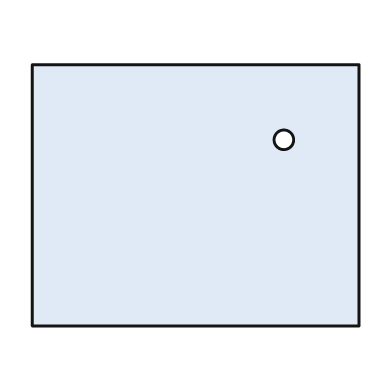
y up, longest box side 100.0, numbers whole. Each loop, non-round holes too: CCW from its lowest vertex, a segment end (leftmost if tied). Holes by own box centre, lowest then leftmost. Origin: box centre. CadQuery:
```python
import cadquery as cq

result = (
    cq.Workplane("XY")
    .moveTo(-50.0, -40.0)
    .lineTo(50.0, -40.0)
    .lineTo(50.0, 40.0)
    .lineTo(-50.0, 40.0)
    .close()
    .moveTo(27.0, 17.0)
    .circle(3.0)
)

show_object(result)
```